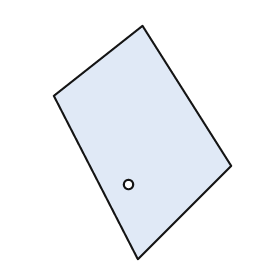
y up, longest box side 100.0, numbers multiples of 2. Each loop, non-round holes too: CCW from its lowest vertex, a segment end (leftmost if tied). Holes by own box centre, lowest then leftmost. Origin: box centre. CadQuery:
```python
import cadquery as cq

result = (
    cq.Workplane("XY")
    .moveTo(-2.0, -50.0)
    .lineTo(38.0, -10.0)
    .lineTo(0.0, 50.0)
    .lineTo(-38.0, 20.0)
    .close()
    .moveTo(-6.0, -18.0)
    .circle(2.0)
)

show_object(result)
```